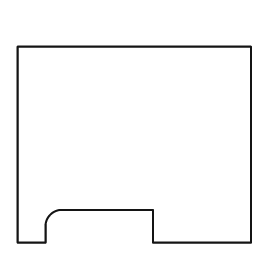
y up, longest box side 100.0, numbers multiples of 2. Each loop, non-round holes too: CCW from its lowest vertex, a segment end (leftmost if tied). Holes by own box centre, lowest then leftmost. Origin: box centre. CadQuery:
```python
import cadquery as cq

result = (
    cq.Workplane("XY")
    .moveTo(-50.0, -42.0)
    .lineTo(-38.0, -42.0)
    .lineTo(-38.0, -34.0)
    .threePointArc((-36.0, -30.0), (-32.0, -28.0))
    .lineTo(8.0, -28.0)
    .lineTo(8.0, -42.0)
    .lineTo(50.0, -42.0)
    .lineTo(50.0, 42.0)
    .lineTo(-50.0, 42.0)
    .close()
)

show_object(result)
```